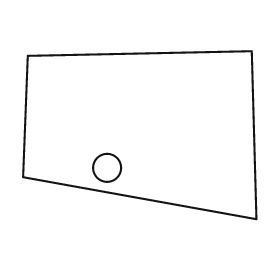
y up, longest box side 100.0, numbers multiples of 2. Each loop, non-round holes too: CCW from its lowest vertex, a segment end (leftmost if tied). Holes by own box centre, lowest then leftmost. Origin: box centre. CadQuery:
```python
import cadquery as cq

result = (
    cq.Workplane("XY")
    .moveTo(50.0, -36.0)
    .lineTo(48.0, 36.0)
    .lineTo(-48.0, 34.0)
    .lineTo(-50.0, -18.0)
    .close()
    .moveTo(-14.0, -14.0)
    .circle(6.0)
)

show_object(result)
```